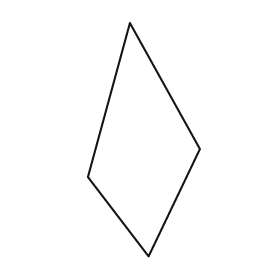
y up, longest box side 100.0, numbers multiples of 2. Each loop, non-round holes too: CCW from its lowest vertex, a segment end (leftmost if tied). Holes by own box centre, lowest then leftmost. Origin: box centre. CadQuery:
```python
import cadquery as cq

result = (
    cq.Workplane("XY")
    .moveTo(2.0, -50.0)
    .lineTo(24.0, -4.0)
    .lineTo(-6.0, 50.0)
    .lineTo(-24.0, -16.0)
    .close()
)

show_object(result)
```